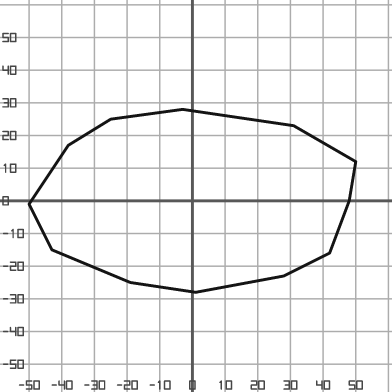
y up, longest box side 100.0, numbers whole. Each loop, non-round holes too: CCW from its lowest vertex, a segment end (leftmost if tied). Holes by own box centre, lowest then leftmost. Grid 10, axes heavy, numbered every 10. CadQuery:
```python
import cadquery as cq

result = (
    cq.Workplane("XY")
    .moveTo(1.0, -28.0)
    .lineTo(28.0, -23.0)
    .lineTo(42.0, -16.0)
    .lineTo(48.0, 0.0)
    .lineTo(50.0, 12.0)
    .lineTo(31.0, 23.0)
    .lineTo(-3.0, 28.0)
    .lineTo(-25.0, 25.0)
    .lineTo(-38.0, 17.0)
    .lineTo(-50.0, -1.0)
    .lineTo(-43.0, -15.0)
    .lineTo(-19.0, -25.0)
    .close()
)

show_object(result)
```